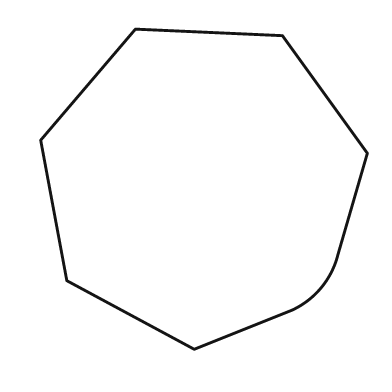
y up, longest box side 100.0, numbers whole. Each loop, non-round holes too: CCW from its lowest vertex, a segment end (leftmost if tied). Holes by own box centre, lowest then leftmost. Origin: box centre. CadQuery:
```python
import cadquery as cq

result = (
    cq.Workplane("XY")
    .moveTo(-3.0, -49.0)
    .lineTo(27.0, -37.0)
    .threePointArc((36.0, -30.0), (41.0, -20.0))
    .lineTo(50.0, 11.0)
    .lineTo(24.0, 47.0)
    .lineTo(-21.0, 49.0)
    .lineTo(-50.0, 15.0)
    .lineTo(-42.0, -28.0)
    .close()
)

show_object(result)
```